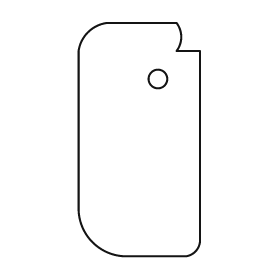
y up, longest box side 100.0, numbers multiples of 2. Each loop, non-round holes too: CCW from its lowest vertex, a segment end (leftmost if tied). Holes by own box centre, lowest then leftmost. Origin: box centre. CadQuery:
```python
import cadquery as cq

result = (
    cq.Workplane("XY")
    .moveTo(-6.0, -50.0)
    .lineTo(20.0, -50.0)
    .threePointArc((24.0, -48.0), (26.0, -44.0))
    .lineTo(26.0, 38.0)
    .lineTo(16.0, 38.0)
    .threePointArc((18.0, 44.0), (16.0, 50.0))
    .lineTo(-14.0, 50.0)
    .threePointArc((-22.0, 46.0), (-26.0, 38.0))
    .lineTo(-26.0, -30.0)
    .threePointArc((-20.0, -44.0), (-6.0, -50.0))
    .close()
    .moveTo(8.0, 26.0)
    .circle(4.0)
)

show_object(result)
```